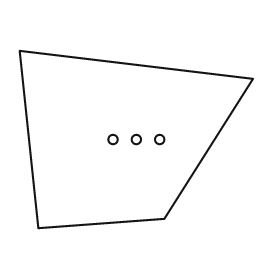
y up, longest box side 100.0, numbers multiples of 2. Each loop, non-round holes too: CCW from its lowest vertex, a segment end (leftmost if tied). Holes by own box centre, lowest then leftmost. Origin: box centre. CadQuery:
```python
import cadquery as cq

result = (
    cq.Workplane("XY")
    .moveTo(-42.0, -38.0)
    .lineTo(12.0, -34.0)
    .lineTo(50.0, 26.0)
    .lineTo(-50.0, 38.0)
    .close()
    .moveTo(-10.0, 0.0)
    .circle(2.0)
    .moveTo(0.0, 0.0)
    .circle(2.0)
    .moveTo(10.0, 0.0)
    .circle(2.0)
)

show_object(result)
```